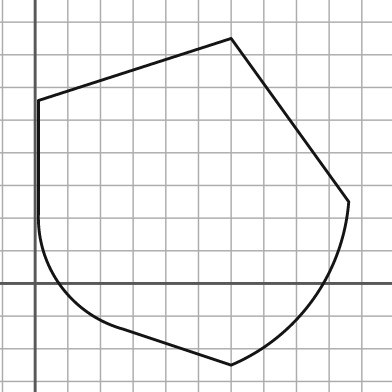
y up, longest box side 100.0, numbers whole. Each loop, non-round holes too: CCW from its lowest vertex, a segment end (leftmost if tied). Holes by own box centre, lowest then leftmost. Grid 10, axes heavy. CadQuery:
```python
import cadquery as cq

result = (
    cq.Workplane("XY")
    .moveTo(60.0, -25.0)
    .threePointArc((85.0, -5.0), (96.0, 25.0))
    .lineTo(60.0, 75.0)
    .lineTo(1.0, 56.0)
    .lineTo(1.0, 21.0)
    .threePointArc((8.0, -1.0), (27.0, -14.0))
    .close()
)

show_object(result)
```